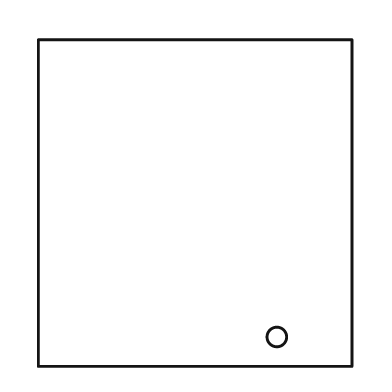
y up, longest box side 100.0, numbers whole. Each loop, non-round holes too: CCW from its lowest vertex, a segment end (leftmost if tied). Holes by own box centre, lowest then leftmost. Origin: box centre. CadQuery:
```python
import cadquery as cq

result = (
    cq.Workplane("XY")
    .moveTo(-48.0, -50.0)
    .lineTo(48.0, -50.0)
    .lineTo(48.0, 50.0)
    .lineTo(-48.0, 50.0)
    .close()
    .moveTo(25.0, -41.0)
    .circle(3.0)
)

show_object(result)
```